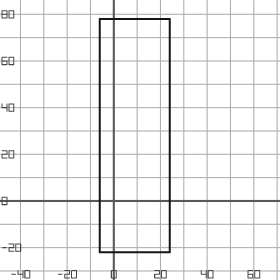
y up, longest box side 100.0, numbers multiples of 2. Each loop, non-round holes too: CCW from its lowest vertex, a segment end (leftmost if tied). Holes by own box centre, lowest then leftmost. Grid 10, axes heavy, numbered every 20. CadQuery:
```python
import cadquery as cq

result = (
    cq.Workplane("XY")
    .moveTo(-6.0, -22.0)
    .lineTo(24.0, -22.0)
    .lineTo(24.0, 78.0)
    .lineTo(-6.0, 78.0)
    .close()
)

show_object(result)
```